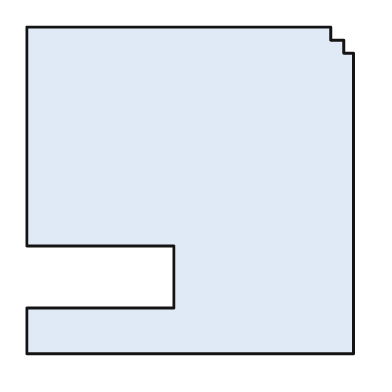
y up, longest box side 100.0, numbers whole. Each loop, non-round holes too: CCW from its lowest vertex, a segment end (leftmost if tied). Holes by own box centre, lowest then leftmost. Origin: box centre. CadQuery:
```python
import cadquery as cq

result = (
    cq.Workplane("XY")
    .moveTo(-50.0, -50.0)
    .lineTo(50.0, -50.0)
    .lineTo(50.0, 42.0)
    .lineTo(47.0, 42.0)
    .lineTo(47.0, 46.0)
    .lineTo(43.0, 46.0)
    .lineTo(43.0, 50.0)
    .lineTo(-50.0, 50.0)
    .lineTo(-50.0, -17.0)
    .lineTo(-5.0, -17.0)
    .lineTo(-5.0, -36.0)
    .lineTo(-50.0, -36.0)
    .close()
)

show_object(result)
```